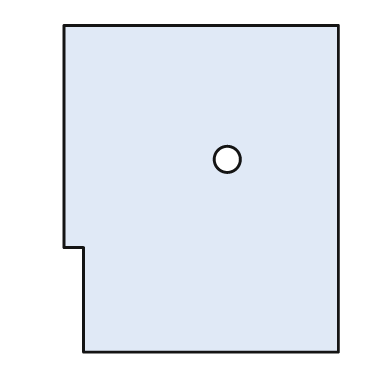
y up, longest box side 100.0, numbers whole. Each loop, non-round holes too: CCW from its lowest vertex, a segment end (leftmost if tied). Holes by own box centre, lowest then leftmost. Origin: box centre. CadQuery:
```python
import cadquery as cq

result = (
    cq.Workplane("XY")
    .moveTo(-36.0, -50.0)
    .lineTo(42.0, -50.0)
    .lineTo(42.0, 50.0)
    .lineTo(-42.0, 50.0)
    .lineTo(-42.0, -18.0)
    .lineTo(-36.0, -18.0)
    .close()
    .moveTo(8.0, 9.0)
    .circle(4.0)
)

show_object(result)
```